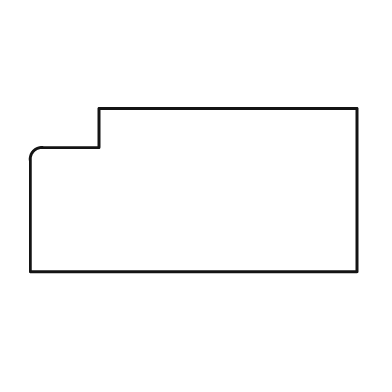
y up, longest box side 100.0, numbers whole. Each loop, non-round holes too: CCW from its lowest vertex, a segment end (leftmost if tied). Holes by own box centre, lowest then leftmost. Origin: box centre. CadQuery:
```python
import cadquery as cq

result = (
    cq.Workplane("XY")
    .moveTo(-50.0, -25.0)
    .lineTo(50.0, -25.0)
    .lineTo(50.0, 25.0)
    .lineTo(-29.0, 25.0)
    .lineTo(-29.0, 13.0)
    .lineTo(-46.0, 13.0)
    .threePointArc((-49.0, 12.0), (-50.0, 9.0))
    .close()
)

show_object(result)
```